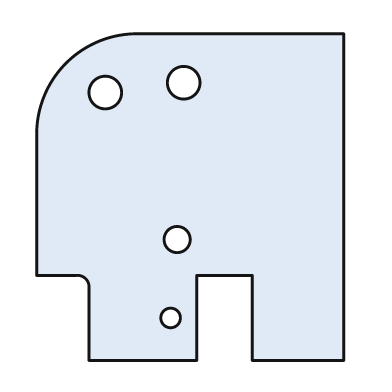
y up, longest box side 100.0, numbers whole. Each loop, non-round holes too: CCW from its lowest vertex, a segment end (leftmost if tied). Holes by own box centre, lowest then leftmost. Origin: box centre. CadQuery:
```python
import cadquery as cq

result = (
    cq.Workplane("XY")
    .moveTo(-31.0, -50.0)
    .lineTo(2.0, -50.0)
    .lineTo(2.0, -24.0)
    .lineTo(19.0, -24.0)
    .lineTo(19.0, -50.0)
    .lineTo(47.0, -50.0)
    .lineTo(47.0, 50.0)
    .lineTo(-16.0, 50.0)
    .threePointArc((-38.0, 41.0), (-47.0, 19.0))
    .lineTo(-47.0, -24.0)
    .lineTo(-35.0, -24.0)
    .threePointArc((-32.0, -25.0), (-31.0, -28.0))
    .close()
    .moveTo(-6.0, -37.0)
    .circle(3.0)
    .moveTo(-4.0, -13.0)
    .circle(4.0)
    .moveTo(-26.0, 32.0)
    .circle(5.0)
    .moveTo(-2.0, 35.0)
    .circle(5.0)
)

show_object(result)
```